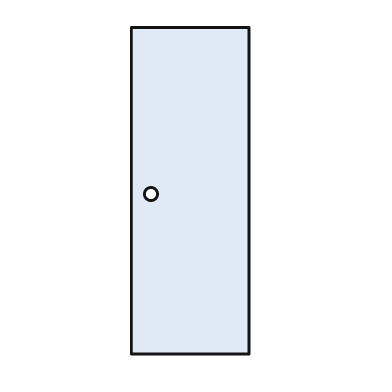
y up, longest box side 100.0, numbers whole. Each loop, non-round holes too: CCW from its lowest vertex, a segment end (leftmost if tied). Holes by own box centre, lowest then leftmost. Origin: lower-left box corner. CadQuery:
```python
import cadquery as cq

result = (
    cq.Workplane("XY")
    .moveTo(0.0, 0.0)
    .lineTo(36.0, 0.0)
    .lineTo(36.0, 100.0)
    .lineTo(0.0, 100.0)
    .close()
    .moveTo(6.0, 49.0)
    .circle(2.0)
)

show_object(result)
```